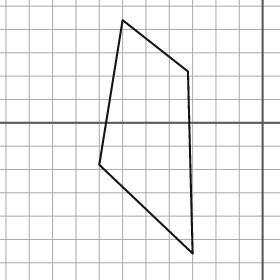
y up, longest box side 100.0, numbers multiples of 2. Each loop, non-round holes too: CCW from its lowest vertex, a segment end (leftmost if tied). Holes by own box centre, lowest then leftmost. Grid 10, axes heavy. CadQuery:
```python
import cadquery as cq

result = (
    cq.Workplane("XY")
    .moveTo(-30.0, -56.0)
    .lineTo(-32.0, 22.0)
    .lineTo(-60.0, 44.0)
    .lineTo(-70.0, -18.0)
    .close()
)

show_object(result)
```